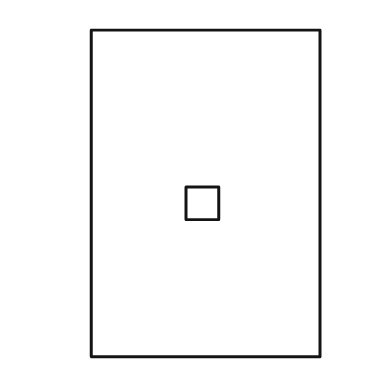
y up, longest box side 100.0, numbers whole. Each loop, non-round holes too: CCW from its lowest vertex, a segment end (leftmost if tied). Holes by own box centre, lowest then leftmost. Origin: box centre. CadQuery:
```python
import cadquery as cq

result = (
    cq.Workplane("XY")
    .moveTo(-35.0, -50.0)
    .lineTo(35.0, -50.0)
    .lineTo(35.0, 50.0)
    .lineTo(-35.0, 50.0)
    .close()
    .moveTo(-6.0, -8.0)
    .lineTo(4.0, -8.0)
    .lineTo(4.0, 2.0)
    .lineTo(-6.0, 2.0)
    .close()
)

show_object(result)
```